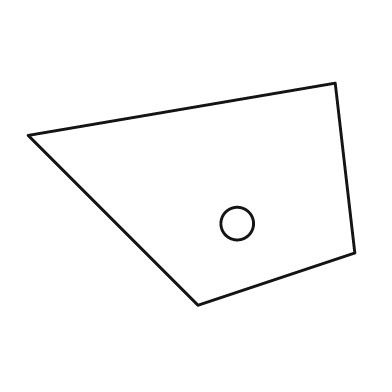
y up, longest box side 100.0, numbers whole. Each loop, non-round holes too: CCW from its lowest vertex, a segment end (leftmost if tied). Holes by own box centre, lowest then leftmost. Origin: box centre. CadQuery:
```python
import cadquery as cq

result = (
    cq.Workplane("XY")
    .moveTo(2.0, -34.0)
    .lineTo(50.0, -18.0)
    .lineTo(44.0, 34.0)
    .lineTo(-50.0, 18.0)
    .close()
    .moveTo(14.0, -9.0)
    .circle(5.0)
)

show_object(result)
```